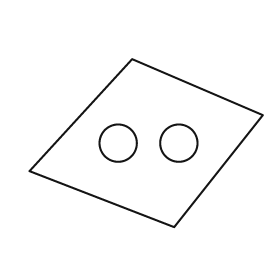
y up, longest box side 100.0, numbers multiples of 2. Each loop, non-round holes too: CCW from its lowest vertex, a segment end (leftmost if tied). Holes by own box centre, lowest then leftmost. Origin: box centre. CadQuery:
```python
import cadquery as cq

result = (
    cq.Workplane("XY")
    .moveTo(12.0, -36.0)
    .lineTo(50.0, 12.0)
    .lineTo(-6.0, 36.0)
    .lineTo(-50.0, -12.0)
    .close()
    .moveTo(-12.0, 0.0)
    .circle(8.0)
    .moveTo(14.0, 0.0)
    .circle(8.0)
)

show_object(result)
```